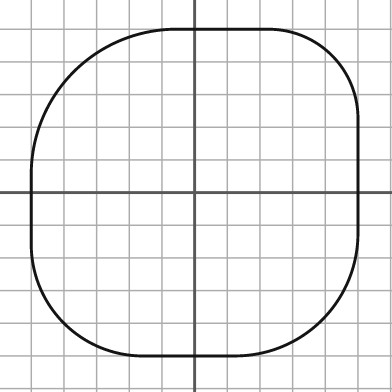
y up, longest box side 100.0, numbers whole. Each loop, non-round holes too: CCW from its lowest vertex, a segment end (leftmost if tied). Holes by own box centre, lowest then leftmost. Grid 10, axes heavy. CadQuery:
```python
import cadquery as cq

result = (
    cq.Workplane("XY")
    .moveTo(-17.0, -50.0)
    .lineTo(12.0, -50.0)
    .threePointArc((39.0, -39.0), (50.0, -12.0))
    .lineTo(50.0, 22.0)
    .threePointArc((42.0, 42.0), (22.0, 50.0))
    .lineTo(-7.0, 50.0)
    .threePointArc((-37.0, 37.0), (-50.0, 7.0))
    .lineTo(-50.0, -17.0)
    .threePointArc((-40.0, -40.0), (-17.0, -50.0))
    .close()
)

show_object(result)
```